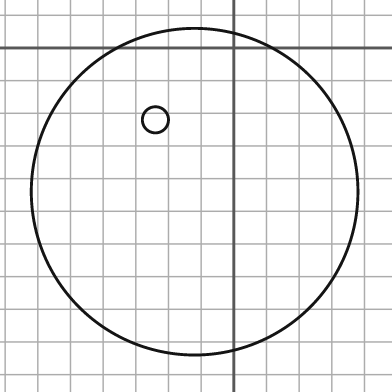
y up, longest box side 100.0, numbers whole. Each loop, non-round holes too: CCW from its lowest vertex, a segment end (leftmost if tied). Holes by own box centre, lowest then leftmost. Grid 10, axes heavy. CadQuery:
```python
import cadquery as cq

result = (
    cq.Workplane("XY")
    .moveTo(-12.0, -44.0)
    .circle(50.0)
    .moveTo(-24.0, -22.0)
    .circle(4.0)
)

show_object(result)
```